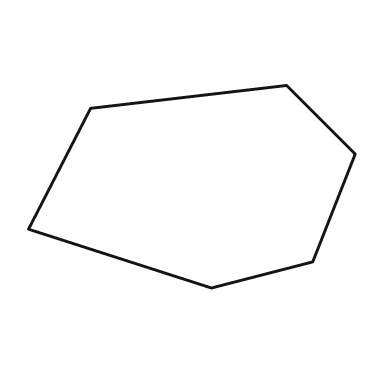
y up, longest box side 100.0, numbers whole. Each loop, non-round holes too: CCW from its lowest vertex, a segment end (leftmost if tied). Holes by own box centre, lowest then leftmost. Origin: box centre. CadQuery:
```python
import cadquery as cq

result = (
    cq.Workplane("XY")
    .moveTo(6.0, -31.0)
    .lineTo(37.0, -23.0)
    .lineTo(50.0, 10.0)
    .lineTo(29.0, 31.0)
    .lineTo(-31.0, 24.0)
    .lineTo(-50.0, -13.0)
    .close()
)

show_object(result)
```